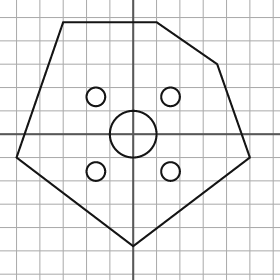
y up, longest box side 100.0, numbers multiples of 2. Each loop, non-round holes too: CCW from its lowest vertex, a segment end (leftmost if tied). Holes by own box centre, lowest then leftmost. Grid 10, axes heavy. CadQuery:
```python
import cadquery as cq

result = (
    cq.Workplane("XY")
    .moveTo(0.0, -48.0)
    .lineTo(50.0, -10.0)
    .lineTo(36.0, 30.0)
    .lineTo(10.0, 48.0)
    .lineTo(-30.0, 48.0)
    .lineTo(-50.0, -10.0)
    .close()
    .moveTo(-16.0, -16.0)
    .circle(4.0)
    .moveTo(16.0, -16.0)
    .circle(4.0)
    .moveTo(0.0, 0.0)
    .circle(10.0)
    .moveTo(-16.0, 16.0)
    .circle(4.0)
    .moveTo(16.0, 16.0)
    .circle(4.0)
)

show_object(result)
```